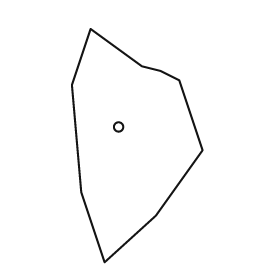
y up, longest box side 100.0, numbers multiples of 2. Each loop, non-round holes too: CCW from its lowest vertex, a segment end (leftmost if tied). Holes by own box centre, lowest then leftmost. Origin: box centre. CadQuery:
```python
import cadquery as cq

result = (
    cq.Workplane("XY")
    .moveTo(-14.0, -50.0)
    .lineTo(8.0, -30.0)
    .lineTo(28.0, -2.0)
    .lineTo(18.0, 28.0)
    .lineTo(10.0, 32.0)
    .lineTo(2.0, 34.0)
    .lineTo(-20.0, 50.0)
    .lineTo(-28.0, 26.0)
    .lineTo(-24.0, -20.0)
    .close()
    .moveTo(-8.0, 8.0)
    .circle(2.0)
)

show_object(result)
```